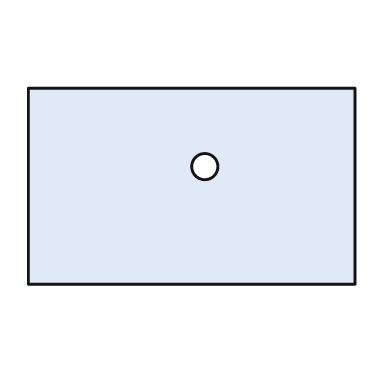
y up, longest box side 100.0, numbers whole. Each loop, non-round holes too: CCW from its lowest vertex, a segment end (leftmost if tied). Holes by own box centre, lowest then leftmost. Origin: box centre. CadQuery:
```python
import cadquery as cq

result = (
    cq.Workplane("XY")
    .moveTo(-50.0, -30.0)
    .lineTo(50.0, -30.0)
    .lineTo(50.0, 30.0)
    .lineTo(-50.0, 30.0)
    .close()
    .moveTo(4.0, 6.0)
    .circle(4.0)
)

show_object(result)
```